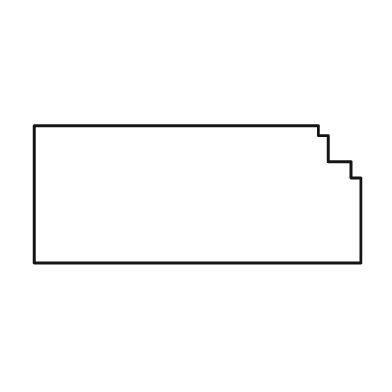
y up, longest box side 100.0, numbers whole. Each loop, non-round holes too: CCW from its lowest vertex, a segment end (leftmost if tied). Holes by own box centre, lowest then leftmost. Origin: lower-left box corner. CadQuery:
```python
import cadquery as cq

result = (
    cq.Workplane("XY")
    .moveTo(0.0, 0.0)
    .lineTo(100.0, 0.0)
    .lineTo(100.0, 26.0)
    .lineTo(97.0, 26.0)
    .lineTo(97.0, 31.0)
    .lineTo(90.0, 31.0)
    .lineTo(90.0, 39.0)
    .lineTo(87.0, 39.0)
    .lineTo(87.0, 42.0)
    .lineTo(0.0, 42.0)
    .close()
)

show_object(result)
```